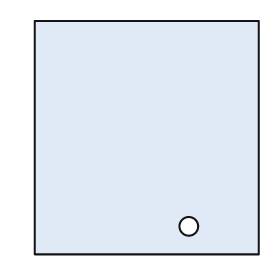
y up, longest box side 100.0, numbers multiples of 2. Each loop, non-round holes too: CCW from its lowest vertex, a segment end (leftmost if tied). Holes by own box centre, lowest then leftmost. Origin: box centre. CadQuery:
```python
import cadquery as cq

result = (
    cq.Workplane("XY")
    .moveTo(-48.0, -50.0)
    .lineTo(48.0, -50.0)
    .lineTo(48.0, 50.0)
    .lineTo(-48.0, 50.0)
    .close()
    .moveTo(18.0, -38.0)
    .circle(4.0)
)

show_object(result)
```